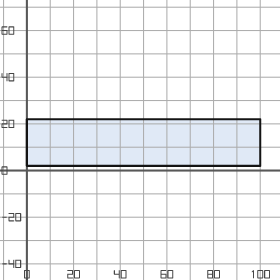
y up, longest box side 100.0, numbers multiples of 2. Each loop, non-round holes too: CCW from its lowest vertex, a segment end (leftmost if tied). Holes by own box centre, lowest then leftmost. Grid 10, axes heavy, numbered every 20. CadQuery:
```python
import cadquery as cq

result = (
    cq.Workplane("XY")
    .moveTo(0.0, 2.0)
    .lineTo(100.0, 2.0)
    .lineTo(100.0, 22.0)
    .lineTo(0.0, 22.0)
    .close()
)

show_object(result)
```